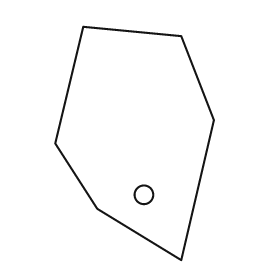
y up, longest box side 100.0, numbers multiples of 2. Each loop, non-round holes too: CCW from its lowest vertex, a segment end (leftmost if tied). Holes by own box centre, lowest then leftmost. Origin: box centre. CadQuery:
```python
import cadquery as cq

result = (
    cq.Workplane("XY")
    .moveTo(20.0, -50.0)
    .lineTo(34.0, 10.0)
    .lineTo(20.0, 46.0)
    .lineTo(-22.0, 50.0)
    .lineTo(-34.0, 0.0)
    .lineTo(-16.0, -28.0)
    .close()
    .moveTo(4.0, -22.0)
    .circle(4.0)
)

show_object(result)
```